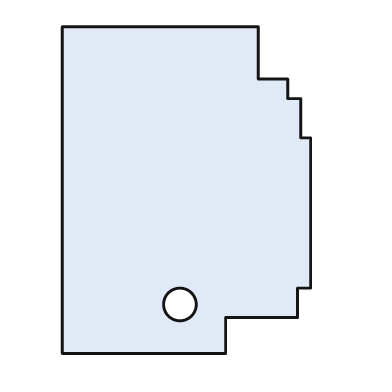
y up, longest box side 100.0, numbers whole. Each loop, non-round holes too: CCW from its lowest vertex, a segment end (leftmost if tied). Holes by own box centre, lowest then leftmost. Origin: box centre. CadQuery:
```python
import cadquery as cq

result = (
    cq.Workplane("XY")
    .moveTo(-38.0, -50.0)
    .lineTo(12.0, -50.0)
    .lineTo(12.0, -39.0)
    .lineTo(34.0, -39.0)
    .lineTo(34.0, -30.0)
    .lineTo(38.0, -30.0)
    .lineTo(38.0, 16.0)
    .lineTo(35.0, 16.0)
    .lineTo(35.0, 28.0)
    .lineTo(31.0, 28.0)
    .lineTo(31.0, 34.0)
    .lineTo(22.0, 34.0)
    .lineTo(22.0, 50.0)
    .lineTo(-38.0, 50.0)
    .close()
    .moveTo(-2.0, -35.0)
    .circle(5.0)
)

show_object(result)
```